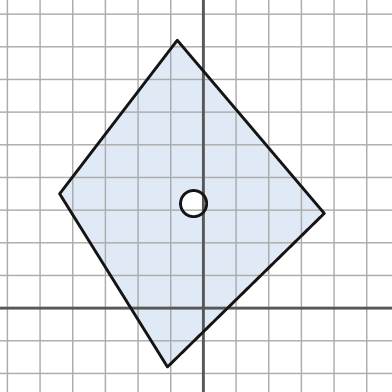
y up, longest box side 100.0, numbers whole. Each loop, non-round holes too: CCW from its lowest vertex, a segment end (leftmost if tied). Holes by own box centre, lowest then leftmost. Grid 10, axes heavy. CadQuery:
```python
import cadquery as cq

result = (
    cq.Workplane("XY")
    .moveTo(-11.0, -18.0)
    .lineTo(37.0, 29.0)
    .lineTo(-8.0, 82.0)
    .lineTo(-44.0, 35.0)
    .close()
    .moveTo(-3.0, 32.0)
    .circle(4.0)
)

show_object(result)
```